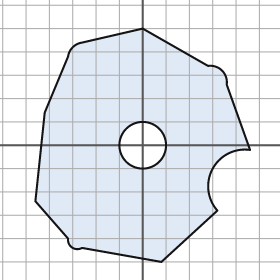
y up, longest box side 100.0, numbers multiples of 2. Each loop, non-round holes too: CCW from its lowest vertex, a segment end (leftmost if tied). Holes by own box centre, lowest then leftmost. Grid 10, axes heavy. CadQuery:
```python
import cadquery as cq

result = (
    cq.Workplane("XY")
    .moveTo(8.0, -50.0)
    .lineTo(32.0, -28.0)
    .threePointArc((30.0, -10.0), (46.0, -2.0))
    .lineTo(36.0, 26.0)
    .threePointArc((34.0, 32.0), (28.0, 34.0))
    .lineTo(0.0, 50.0)
    .lineTo(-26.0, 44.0)
    .threePointArc((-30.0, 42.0), (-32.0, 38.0))
    .lineTo(-42.0, 14.0)
    .lineTo(-46.0, -24.0)
    .lineTo(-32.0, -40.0)
    .threePointArc((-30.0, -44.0), (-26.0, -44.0))
    .close()
    .moveTo(0.0, 0.0)
    .circle(10.0)
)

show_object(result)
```